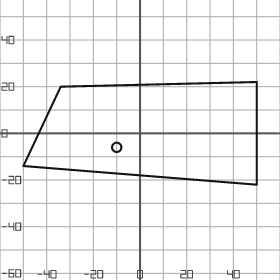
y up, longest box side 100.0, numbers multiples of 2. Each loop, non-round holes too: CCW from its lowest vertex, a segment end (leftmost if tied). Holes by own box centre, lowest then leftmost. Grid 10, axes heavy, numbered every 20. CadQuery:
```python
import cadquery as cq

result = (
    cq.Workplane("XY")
    .moveTo(50.0, -22.0)
    .lineTo(50.0, 22.0)
    .lineTo(-34.0, 20.0)
    .lineTo(-50.0, -14.0)
    .close()
    .moveTo(-10.0, -6.0)
    .circle(2.0)
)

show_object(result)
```